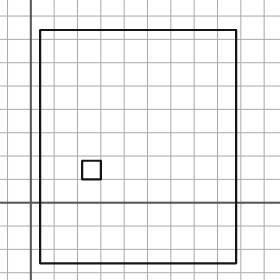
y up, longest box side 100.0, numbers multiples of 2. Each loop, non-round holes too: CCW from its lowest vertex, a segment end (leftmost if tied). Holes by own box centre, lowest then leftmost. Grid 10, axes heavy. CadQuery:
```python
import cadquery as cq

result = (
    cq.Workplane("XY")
    .moveTo(4.0, -26.0)
    .lineTo(88.0, -26.0)
    .lineTo(88.0, 74.0)
    .lineTo(4.0, 74.0)
    .close()
    .moveTo(22.0, 10.0)
    .lineTo(30.0, 10.0)
    .lineTo(30.0, 18.0)
    .lineTo(22.0, 18.0)
    .close()
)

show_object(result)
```